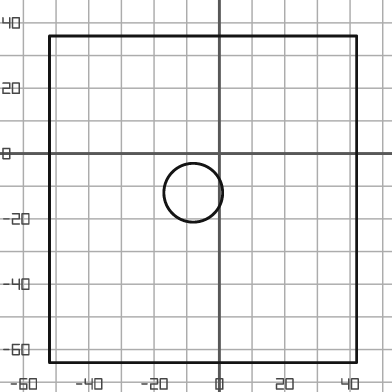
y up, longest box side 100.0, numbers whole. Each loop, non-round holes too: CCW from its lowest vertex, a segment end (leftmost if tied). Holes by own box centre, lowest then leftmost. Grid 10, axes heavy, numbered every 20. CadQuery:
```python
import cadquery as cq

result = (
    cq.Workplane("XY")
    .moveTo(-52.0, -64.0)
    .lineTo(42.0, -64.0)
    .lineTo(42.0, 36.0)
    .lineTo(-52.0, 36.0)
    .close()
    .moveTo(-8.0, -12.0)
    .circle(9.0)
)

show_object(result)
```